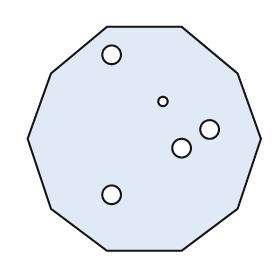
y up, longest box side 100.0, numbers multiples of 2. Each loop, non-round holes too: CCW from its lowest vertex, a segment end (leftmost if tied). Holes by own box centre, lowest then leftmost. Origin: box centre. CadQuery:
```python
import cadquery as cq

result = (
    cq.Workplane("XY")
    .moveTo(-16.0, -48.0)
    .lineTo(16.0, -48.0)
    .lineTo(40.0, -30.0)
    .lineTo(50.0, 0.0)
    .lineTo(40.0, 28.0)
    .lineTo(16.0, 48.0)
    .lineTo(-16.0, 48.0)
    .lineTo(-40.0, 28.0)
    .lineTo(-50.0, 0.0)
    .lineTo(-40.0, -30.0)
    .close()
    .moveTo(-14.0, -24.0)
    .circle(4.0)
    .moveTo(16.0, -4.0)
    .circle(4.0)
    .moveTo(28.0, 4.0)
    .circle(4.0)
    .moveTo(8.0, 16.0)
    .circle(2.0)
    .moveTo(-14.0, 36.0)
    .circle(4.0)
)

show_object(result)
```